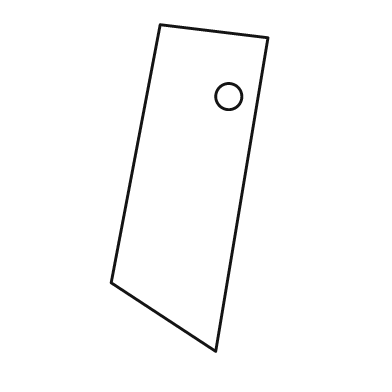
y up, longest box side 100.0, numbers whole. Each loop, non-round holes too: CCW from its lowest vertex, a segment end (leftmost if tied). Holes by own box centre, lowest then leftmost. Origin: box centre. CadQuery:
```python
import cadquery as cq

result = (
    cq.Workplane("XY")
    .moveTo(8.0, -50.0)
    .lineTo(24.0, 46.0)
    .lineTo(-9.0, 50.0)
    .lineTo(-24.0, -29.0)
    .close()
    .moveTo(12.0, 28.0)
    .circle(4.0)
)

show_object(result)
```